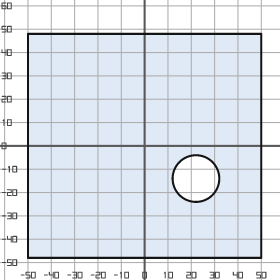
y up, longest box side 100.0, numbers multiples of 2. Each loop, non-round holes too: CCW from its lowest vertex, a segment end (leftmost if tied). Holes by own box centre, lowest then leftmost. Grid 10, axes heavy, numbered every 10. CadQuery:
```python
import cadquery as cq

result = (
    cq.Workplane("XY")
    .moveTo(-50.0, -48.0)
    .lineTo(50.0, -48.0)
    .lineTo(50.0, 48.0)
    .lineTo(-50.0, 48.0)
    .close()
    .moveTo(22.0, -14.0)
    .circle(10.0)
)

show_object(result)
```